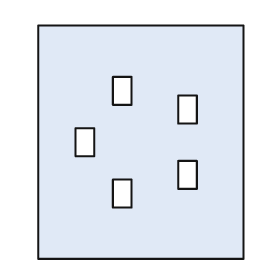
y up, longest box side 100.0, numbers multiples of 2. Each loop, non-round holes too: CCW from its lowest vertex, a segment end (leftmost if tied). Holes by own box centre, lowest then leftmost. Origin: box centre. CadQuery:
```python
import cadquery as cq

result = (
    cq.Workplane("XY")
    .moveTo(-44.0, -50.0)
    .lineTo(44.0, -50.0)
    .lineTo(44.0, 50.0)
    .lineTo(-44.0, 50.0)
    .close()
    .moveTo(-12.0, -28.0)
    .lineTo(-4.0, -28.0)
    .lineTo(-4.0, -16.0)
    .lineTo(-12.0, -16.0)
    .close()
    .moveTo(16.0, -20.0)
    .lineTo(24.0, -20.0)
    .lineTo(24.0, -8.0)
    .lineTo(16.0, -8.0)
    .close()
    .moveTo(-28.0, -6.0)
    .lineTo(-20.0, -6.0)
    .lineTo(-20.0, 6.0)
    .lineTo(-28.0, 6.0)
    .close()
    .moveTo(16.0, 8.0)
    .lineTo(24.0, 8.0)
    .lineTo(24.0, 20.0)
    .lineTo(16.0, 20.0)
    .close()
    .moveTo(-12.0, 16.0)
    .lineTo(-4.0, 16.0)
    .lineTo(-4.0, 28.0)
    .lineTo(-12.0, 28.0)
    .close()
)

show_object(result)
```